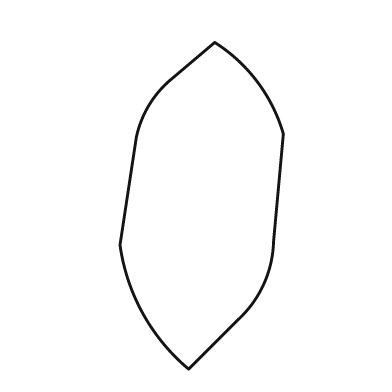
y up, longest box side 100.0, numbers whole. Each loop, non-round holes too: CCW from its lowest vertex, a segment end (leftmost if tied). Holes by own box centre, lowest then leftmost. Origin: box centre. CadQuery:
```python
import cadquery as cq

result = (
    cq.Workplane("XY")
    .moveTo(-4.0, -50.0)
    .lineTo(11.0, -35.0)
    .threePointArc((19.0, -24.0), (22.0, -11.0))
    .lineTo(25.0, 22.0)
    .threePointArc((17.0, 38.0), (4.0, 50.0))
    .lineTo(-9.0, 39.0)
    .threePointArc((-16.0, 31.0), (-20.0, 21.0))
    .lineTo(-25.0, -12.0)
    .threePointArc((-18.0, -33.0), (-4.0, -50.0))
    .close()
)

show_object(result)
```